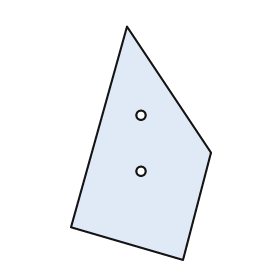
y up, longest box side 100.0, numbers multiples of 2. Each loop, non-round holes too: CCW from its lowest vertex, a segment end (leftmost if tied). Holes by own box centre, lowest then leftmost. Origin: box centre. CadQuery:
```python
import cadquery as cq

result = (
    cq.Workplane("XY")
    .moveTo(18.0, -50.0)
    .lineTo(30.0, -4.0)
    .lineTo(-6.0, 50.0)
    .lineTo(-30.0, -36.0)
    .close()
    .moveTo(0.0, -12.0)
    .circle(2.0)
    .moveTo(0.0, 12.0)
    .circle(2.0)
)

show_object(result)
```